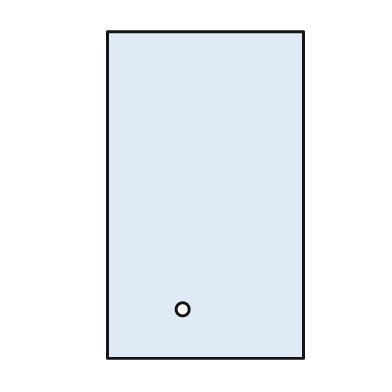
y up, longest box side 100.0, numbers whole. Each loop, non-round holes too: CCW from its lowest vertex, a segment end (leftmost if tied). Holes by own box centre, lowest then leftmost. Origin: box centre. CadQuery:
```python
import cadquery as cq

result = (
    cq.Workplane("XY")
    .moveTo(-30.0, -50.0)
    .lineTo(30.0, -50.0)
    .lineTo(30.0, 50.0)
    .lineTo(-30.0, 50.0)
    .close()
    .moveTo(-7.0, -35.0)
    .circle(2.0)
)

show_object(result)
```